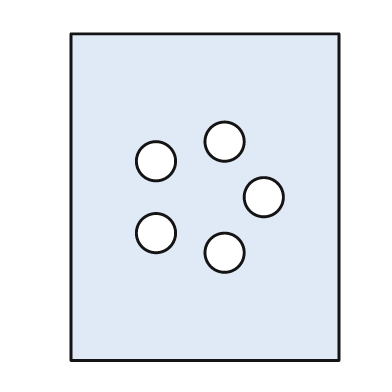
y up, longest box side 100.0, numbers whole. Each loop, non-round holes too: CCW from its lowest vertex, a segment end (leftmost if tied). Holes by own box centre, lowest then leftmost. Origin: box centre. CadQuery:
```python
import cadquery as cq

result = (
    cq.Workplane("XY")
    .moveTo(-41.0, -50.0)
    .lineTo(41.0, -50.0)
    .lineTo(41.0, 50.0)
    .lineTo(-41.0, 50.0)
    .close()
    .moveTo(6.0, -17.0)
    .circle(6.0)
    .moveTo(-15.0, -11.0)
    .circle(6.0)
    .moveTo(18.0, 0.0)
    .circle(6.0)
    .moveTo(-15.0, 11.0)
    .circle(6.0)
    .moveTo(6.0, 17.0)
    .circle(6.0)
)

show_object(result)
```